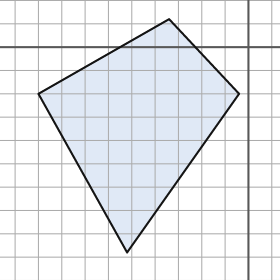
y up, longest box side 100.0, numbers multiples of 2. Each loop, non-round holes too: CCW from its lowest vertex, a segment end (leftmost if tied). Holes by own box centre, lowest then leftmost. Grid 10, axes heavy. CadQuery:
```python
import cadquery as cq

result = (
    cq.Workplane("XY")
    .moveTo(-52.0, -88.0)
    .lineTo(-4.0, -20.0)
    .lineTo(-34.0, 12.0)
    .lineTo(-90.0, -20.0)
    .close()
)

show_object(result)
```